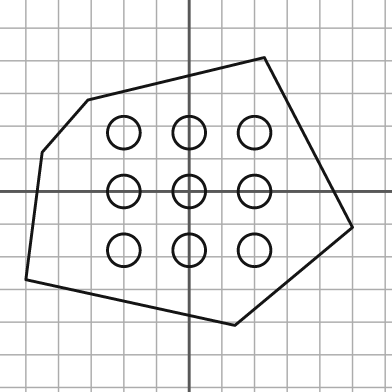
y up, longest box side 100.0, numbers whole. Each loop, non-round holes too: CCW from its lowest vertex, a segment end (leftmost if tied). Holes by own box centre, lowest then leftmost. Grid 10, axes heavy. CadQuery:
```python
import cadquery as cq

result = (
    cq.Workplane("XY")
    .moveTo(14.0, -41.0)
    .lineTo(50.0, -11.0)
    .lineTo(23.0, 41.0)
    .lineTo(-31.0, 28.0)
    .lineTo(-45.0, 12.0)
    .lineTo(-50.0, -27.0)
    .close()
    .moveTo(-20.0, -18.0)
    .circle(5.0)
    .moveTo(0.0, -18.0)
    .circle(5.0)
    .moveTo(20.0, -18.0)
    .circle(5.0)
    .moveTo(-20.0, 0.0)
    .circle(5.0)
    .moveTo(0.0, 0.0)
    .circle(5.0)
    .moveTo(20.0, 0.0)
    .circle(5.0)
    .moveTo(-20.0, 18.0)
    .circle(5.0)
    .moveTo(0.0, 18.0)
    .circle(5.0)
    .moveTo(20.0, 18.0)
    .circle(5.0)
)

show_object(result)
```